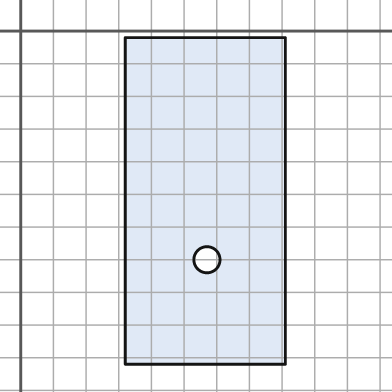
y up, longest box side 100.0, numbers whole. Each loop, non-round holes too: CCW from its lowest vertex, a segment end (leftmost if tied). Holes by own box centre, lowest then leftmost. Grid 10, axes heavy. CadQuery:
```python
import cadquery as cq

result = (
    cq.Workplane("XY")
    .moveTo(32.0, -102.0)
    .lineTo(81.0, -102.0)
    .lineTo(81.0, -2.0)
    .lineTo(32.0, -2.0)
    .close()
    .moveTo(57.0, -70.0)
    .circle(4.0)
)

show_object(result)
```